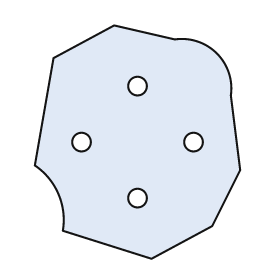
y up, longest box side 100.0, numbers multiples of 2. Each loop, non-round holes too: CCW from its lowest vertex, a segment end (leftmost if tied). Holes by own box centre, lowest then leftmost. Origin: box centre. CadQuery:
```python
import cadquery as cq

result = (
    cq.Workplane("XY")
    .moveTo(6.0, -50.0)
    .lineTo(32.0, -36.0)
    .lineTo(44.0, -12.0)
    .lineTo(40.0, 20.0)
    .threePointArc((34.0, 38.0), (16.0, 44.0))
    .lineTo(-10.0, 50.0)
    .lineTo(-36.0, 36.0)
    .lineTo(-44.0, -10.0)
    .threePointArc((-34.0, -22.0), (-32.0, -38.0))
    .close()
    .moveTo(0.0, -24.0)
    .circle(4.0)
    .moveTo(-24.0, 0.0)
    .circle(4.0)
    .moveTo(24.0, 0.0)
    .circle(4.0)
    .moveTo(0.0, 24.0)
    .circle(4.0)
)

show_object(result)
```